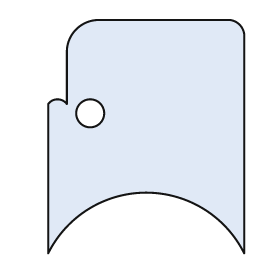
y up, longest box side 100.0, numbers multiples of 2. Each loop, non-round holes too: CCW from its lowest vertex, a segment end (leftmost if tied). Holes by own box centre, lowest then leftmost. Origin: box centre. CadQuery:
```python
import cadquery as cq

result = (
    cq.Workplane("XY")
    .moveTo(-42.0, -50.0)
    .threePointArc((0.0, -24.0), (42.0, -50.0))
    .lineTo(42.0, 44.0)
    .threePointArc((40.0, 48.0), (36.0, 50.0))
    .lineTo(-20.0, 50.0)
    .threePointArc((-30.0, 46.0), (-34.0, 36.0))
    .lineTo(-34.0, 14.0)
    .threePointArc((-38.0, 16.0), (-42.0, 14.0))
    .close()
    .moveTo(-24.0, 10.0)
    .circle(6.0)
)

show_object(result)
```